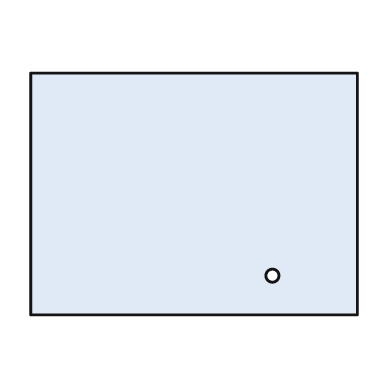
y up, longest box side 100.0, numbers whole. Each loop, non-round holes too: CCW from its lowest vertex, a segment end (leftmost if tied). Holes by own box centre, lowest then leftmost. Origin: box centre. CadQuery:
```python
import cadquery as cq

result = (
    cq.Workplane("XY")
    .moveTo(-50.0, -37.0)
    .lineTo(50.0, -37.0)
    .lineTo(50.0, 37.0)
    .lineTo(-50.0, 37.0)
    .close()
    .moveTo(24.0, -25.0)
    .circle(2.0)
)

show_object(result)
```